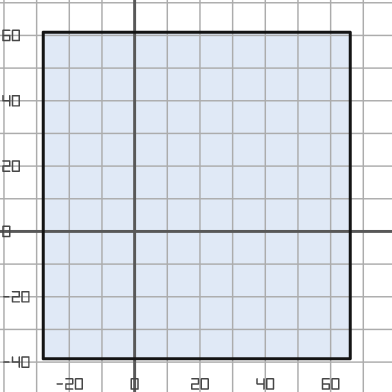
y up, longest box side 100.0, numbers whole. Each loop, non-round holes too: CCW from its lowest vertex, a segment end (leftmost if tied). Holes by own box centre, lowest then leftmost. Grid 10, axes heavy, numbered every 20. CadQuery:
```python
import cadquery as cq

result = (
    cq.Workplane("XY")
    .moveTo(-28.0, -39.0)
    .lineTo(66.0, -39.0)
    .lineTo(66.0, 61.0)
    .lineTo(-28.0, 61.0)
    .close()
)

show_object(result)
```